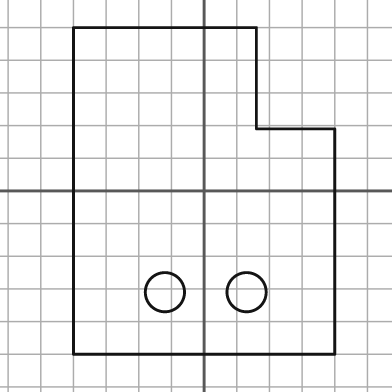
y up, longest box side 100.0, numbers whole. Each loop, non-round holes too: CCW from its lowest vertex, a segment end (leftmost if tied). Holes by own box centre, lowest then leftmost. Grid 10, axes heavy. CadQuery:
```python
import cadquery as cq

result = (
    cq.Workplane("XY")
    .moveTo(-40.0, -50.0)
    .lineTo(40.0, -50.0)
    .lineTo(40.0, 19.0)
    .lineTo(16.0, 19.0)
    .lineTo(16.0, 50.0)
    .lineTo(-40.0, 50.0)
    .close()
    .moveTo(-12.0, -31.0)
    .circle(6.0)
    .moveTo(13.0, -31.0)
    .circle(6.0)
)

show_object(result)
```